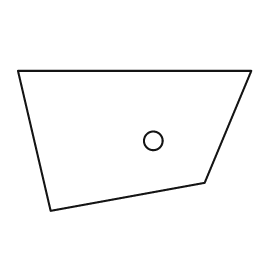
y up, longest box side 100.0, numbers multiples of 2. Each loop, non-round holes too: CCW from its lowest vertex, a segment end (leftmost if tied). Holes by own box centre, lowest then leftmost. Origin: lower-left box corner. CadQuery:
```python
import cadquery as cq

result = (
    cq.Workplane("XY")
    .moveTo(14.0, 0.0)
    .lineTo(80.0, 12.0)
    .lineTo(100.0, 60.0)
    .lineTo(0.0, 60.0)
    .close()
    .moveTo(58.0, 30.0)
    .circle(4.0)
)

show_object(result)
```